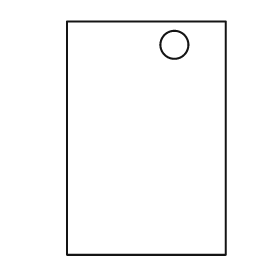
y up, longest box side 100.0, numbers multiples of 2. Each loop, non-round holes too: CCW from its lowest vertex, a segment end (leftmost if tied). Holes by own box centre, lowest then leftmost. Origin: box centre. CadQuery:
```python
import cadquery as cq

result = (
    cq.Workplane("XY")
    .moveTo(-34.0, -50.0)
    .lineTo(34.0, -50.0)
    .lineTo(34.0, 50.0)
    .lineTo(-34.0, 50.0)
    .close()
    .moveTo(12.0, 40.0)
    .circle(6.0)
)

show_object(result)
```